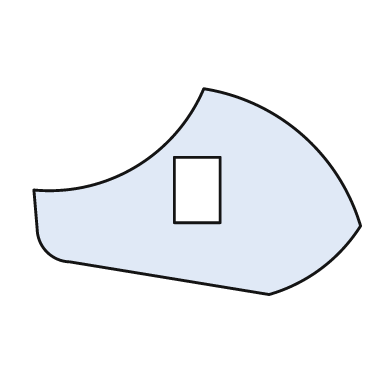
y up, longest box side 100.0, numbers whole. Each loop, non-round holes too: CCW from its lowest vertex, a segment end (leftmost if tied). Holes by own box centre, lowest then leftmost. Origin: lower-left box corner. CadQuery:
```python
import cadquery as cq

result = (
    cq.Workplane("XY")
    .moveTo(72.0, 0.0)
    .threePointArc((88.0, 8.0), (100.0, 21.0))
    .threePointArc((82.0, 49.0), (52.0, 63.0))
    .threePointArc((31.0, 39.0), (0.0, 32.0))
    .lineTo(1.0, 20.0)
    .threePointArc((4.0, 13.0), (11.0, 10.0))
    .close()
    .moveTo(43.0, 22.0)
    .lineTo(57.0, 22.0)
    .lineTo(57.0, 42.0)
    .lineTo(43.0, 42.0)
    .close()
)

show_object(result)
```